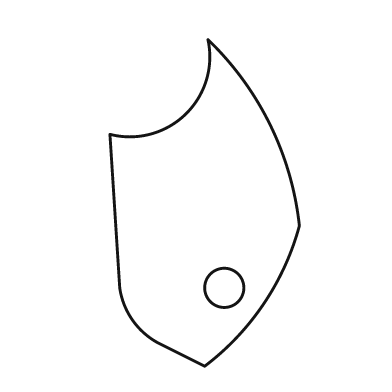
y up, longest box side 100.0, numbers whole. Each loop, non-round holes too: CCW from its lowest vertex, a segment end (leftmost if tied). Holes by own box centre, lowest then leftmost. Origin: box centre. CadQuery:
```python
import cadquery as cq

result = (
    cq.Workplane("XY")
    .moveTo(0.0, -50.0)
    .threePointArc((18.0, -31.0), (29.0, -7.0))
    .threePointArc((20.0, 24.0), (1.0, 50.0))
    .threePointArc((-6.0, 27.0), (-29.0, 21.0))
    .lineTo(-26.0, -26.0)
    .threePointArc((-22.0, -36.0), (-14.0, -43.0))
    .close()
    .moveTo(6.0, -26.0)
    .circle(6.0)
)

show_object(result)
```